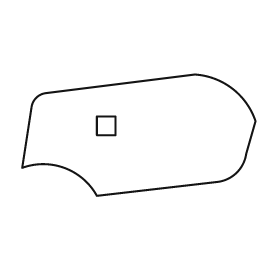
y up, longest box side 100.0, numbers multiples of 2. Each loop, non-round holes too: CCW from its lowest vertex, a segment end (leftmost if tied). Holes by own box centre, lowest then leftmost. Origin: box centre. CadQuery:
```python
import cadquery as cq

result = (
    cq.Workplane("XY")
    .moveTo(-18.0, -26.0)
    .lineTo(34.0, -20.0)
    .threePointArc((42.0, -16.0), (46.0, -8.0))
    .lineTo(50.0, 6.0)
    .threePointArc((40.0, 20.0), (24.0, 26.0))
    .lineTo(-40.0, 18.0)
    .threePointArc((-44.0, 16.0), (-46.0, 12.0))
    .lineTo(-50.0, -14.0)
    .threePointArc((-32.0, -14.0), (-18.0, -26.0))
    .close()
    .moveTo(-18.0, 0.0)
    .lineTo(-10.0, 0.0)
    .lineTo(-10.0, 8.0)
    .lineTo(-18.0, 8.0)
    .close()
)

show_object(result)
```